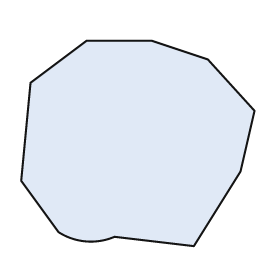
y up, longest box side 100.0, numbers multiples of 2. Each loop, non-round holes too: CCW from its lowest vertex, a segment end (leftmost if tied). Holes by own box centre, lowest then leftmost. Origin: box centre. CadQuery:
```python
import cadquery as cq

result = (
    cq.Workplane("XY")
    .moveTo(24.0, -44.0)
    .lineTo(44.0, -12.0)
    .lineTo(50.0, 14.0)
    .lineTo(30.0, 36.0)
    .lineTo(6.0, 44.0)
    .lineTo(-22.0, 44.0)
    .lineTo(-46.0, 26.0)
    .lineTo(-50.0, -16.0)
    .lineTo(-34.0, -38.0)
    .threePointArc((-22.0, -42.0), (-10.0, -40.0))
    .close()
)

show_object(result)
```